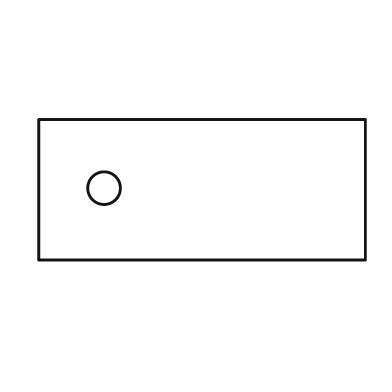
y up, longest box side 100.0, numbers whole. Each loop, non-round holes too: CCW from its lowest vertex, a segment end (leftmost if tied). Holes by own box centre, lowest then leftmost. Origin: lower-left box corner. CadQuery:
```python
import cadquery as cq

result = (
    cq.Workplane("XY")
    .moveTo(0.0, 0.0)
    .lineTo(100.0, 0.0)
    .lineTo(100.0, 43.0)
    .lineTo(0.0, 43.0)
    .close()
    .moveTo(20.0, 22.0)
    .circle(5.0)
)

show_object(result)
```